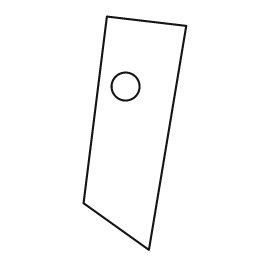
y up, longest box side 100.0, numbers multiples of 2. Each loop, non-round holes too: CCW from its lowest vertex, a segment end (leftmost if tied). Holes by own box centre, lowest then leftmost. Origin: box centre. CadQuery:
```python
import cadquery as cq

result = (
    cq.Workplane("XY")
    .moveTo(6.0, -50.0)
    .lineTo(22.0, 46.0)
    .lineTo(-12.0, 50.0)
    .lineTo(-22.0, -30.0)
    .close()
    .moveTo(-4.0, 20.0)
    .circle(6.0)
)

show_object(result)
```